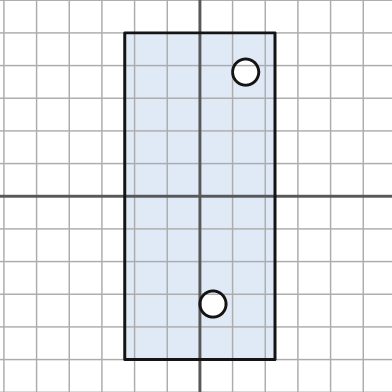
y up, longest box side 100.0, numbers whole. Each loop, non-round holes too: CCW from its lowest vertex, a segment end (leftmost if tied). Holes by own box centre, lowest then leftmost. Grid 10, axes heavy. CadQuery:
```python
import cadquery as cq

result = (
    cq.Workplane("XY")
    .moveTo(-23.0, -50.0)
    .lineTo(23.0, -50.0)
    .lineTo(23.0, 50.0)
    .lineTo(-23.0, 50.0)
    .close()
    .moveTo(4.0, -33.0)
    .circle(4.0)
    .moveTo(14.0, 38.0)
    .circle(4.0)
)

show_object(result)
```